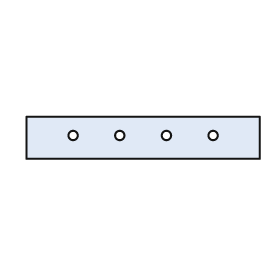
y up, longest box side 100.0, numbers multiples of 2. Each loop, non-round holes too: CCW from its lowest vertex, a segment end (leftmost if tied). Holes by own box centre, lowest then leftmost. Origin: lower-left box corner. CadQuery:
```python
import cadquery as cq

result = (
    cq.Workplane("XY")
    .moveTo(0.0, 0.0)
    .lineTo(100.0, 0.0)
    .lineTo(100.0, 18.0)
    .lineTo(0.0, 18.0)
    .close()
    .moveTo(20.0, 10.0)
    .circle(2.0)
    .moveTo(40.0, 10.0)
    .circle(2.0)
    .moveTo(60.0, 10.0)
    .circle(2.0)
    .moveTo(80.0, 10.0)
    .circle(2.0)
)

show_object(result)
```